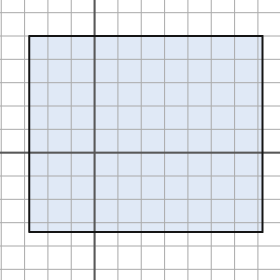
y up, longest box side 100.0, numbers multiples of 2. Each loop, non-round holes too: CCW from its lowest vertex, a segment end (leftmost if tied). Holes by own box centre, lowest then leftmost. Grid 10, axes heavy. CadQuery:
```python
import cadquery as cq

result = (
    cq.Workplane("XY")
    .moveTo(-28.0, -34.0)
    .lineTo(72.0, -34.0)
    .lineTo(72.0, 50.0)
    .lineTo(-28.0, 50.0)
    .close()
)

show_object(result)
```